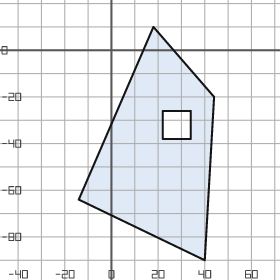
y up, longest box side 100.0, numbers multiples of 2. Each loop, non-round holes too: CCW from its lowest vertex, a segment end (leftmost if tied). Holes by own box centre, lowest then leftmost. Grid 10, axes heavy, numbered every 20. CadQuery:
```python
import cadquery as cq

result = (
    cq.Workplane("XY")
    .moveTo(40.0, -90.0)
    .lineTo(44.0, -20.0)
    .lineTo(18.0, 10.0)
    .lineTo(-14.0, -64.0)
    .close()
    .moveTo(22.0, -38.0)
    .lineTo(34.0, -38.0)
    .lineTo(34.0, -26.0)
    .lineTo(22.0, -26.0)
    .close()
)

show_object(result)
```